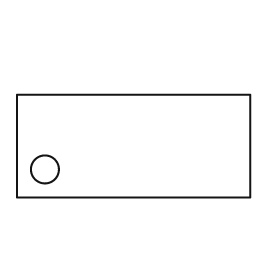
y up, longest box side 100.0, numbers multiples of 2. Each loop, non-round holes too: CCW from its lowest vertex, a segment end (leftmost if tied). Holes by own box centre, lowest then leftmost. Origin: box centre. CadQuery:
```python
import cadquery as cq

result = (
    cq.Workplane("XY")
    .moveTo(-50.0, -22.0)
    .lineTo(50.0, -22.0)
    .lineTo(50.0, 22.0)
    .lineTo(-50.0, 22.0)
    .close()
    .moveTo(-38.0, -10.0)
    .circle(6.0)
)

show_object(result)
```